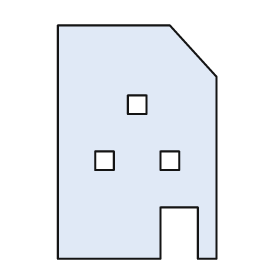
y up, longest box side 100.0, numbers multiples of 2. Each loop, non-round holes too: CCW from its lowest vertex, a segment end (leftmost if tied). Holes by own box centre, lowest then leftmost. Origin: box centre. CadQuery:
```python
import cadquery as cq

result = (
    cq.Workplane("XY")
    .moveTo(-34.0, -50.0)
    .lineTo(10.0, -50.0)
    .lineTo(10.0, -28.0)
    .lineTo(26.0, -28.0)
    .lineTo(26.0, -50.0)
    .lineTo(34.0, -50.0)
    .lineTo(34.0, 28.0)
    .lineTo(14.0, 50.0)
    .lineTo(-34.0, 50.0)
    .close()
    .moveTo(-18.0, -12.0)
    .lineTo(-10.0, -12.0)
    .lineTo(-10.0, -4.0)
    .lineTo(-18.0, -4.0)
    .close()
    .moveTo(10.0, -12.0)
    .lineTo(18.0, -12.0)
    .lineTo(18.0, -4.0)
    .lineTo(10.0, -4.0)
    .close()
    .moveTo(-4.0, 12.0)
    .lineTo(4.0, 12.0)
    .lineTo(4.0, 20.0)
    .lineTo(-4.0, 20.0)
    .close()
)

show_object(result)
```